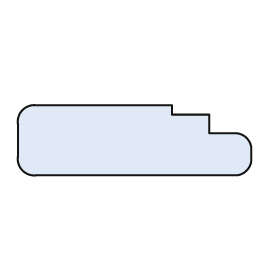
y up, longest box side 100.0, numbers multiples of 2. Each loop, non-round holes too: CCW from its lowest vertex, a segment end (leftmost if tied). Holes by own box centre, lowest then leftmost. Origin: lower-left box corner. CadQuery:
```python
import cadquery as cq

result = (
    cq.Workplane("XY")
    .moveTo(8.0, 0.0)
    .lineTo(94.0, 0.0)
    .threePointArc((98.0, 2.0), (100.0, 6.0))
    .lineTo(100.0, 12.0)
    .threePointArc((98.0, 16.0), (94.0, 18.0))
    .lineTo(82.0, 18.0)
    .lineTo(82.0, 26.0)
    .lineTo(66.0, 26.0)
    .lineTo(66.0, 30.0)
    .lineTo(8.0, 30.0)
    .threePointArc((2.0, 28.0), (0.0, 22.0))
    .lineTo(0.0, 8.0)
    .threePointArc((2.0, 2.0), (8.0, 0.0))
    .close()
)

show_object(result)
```